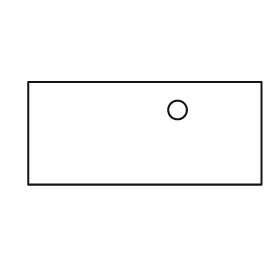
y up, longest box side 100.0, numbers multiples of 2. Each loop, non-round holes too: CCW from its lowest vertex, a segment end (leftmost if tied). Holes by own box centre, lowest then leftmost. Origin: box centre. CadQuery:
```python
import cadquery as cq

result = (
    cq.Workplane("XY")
    .moveTo(-50.0, -22.0)
    .lineTo(50.0, -22.0)
    .lineTo(50.0, 22.0)
    .lineTo(-50.0, 22.0)
    .close()
    .moveTo(14.0, 10.0)
    .circle(4.0)
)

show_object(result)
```